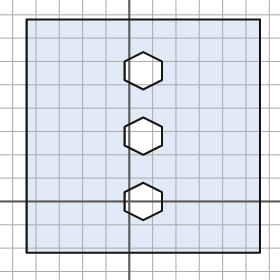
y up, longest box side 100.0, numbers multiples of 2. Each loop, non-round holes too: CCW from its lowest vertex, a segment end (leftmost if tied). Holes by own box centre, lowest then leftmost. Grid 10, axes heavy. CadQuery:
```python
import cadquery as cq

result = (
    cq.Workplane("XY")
    .moveTo(-44.0, -22.0)
    .lineTo(56.0, -22.0)
    .lineTo(56.0, 78.0)
    .lineTo(-44.0, 78.0)
    .close()
    .moveTo(6.0, -8.0)
    .lineTo(14.0, -4.0)
    .lineTo(14.0, 4.0)
    .lineTo(6.0, 8.0)
    .lineTo(-2.0, 4.0)
    .lineTo(-2.0, -4.0)
    .close()
    .moveTo(6.0, 20.0)
    .lineTo(14.0, 24.0)
    .lineTo(14.0, 32.0)
    .lineTo(6.0, 36.0)
    .lineTo(-2.0, 32.0)
    .lineTo(-2.0, 24.0)
    .close()
    .moveTo(6.0, 48.0)
    .lineTo(14.0, 52.0)
    .lineTo(14.0, 60.0)
    .lineTo(6.0, 64.0)
    .lineTo(-2.0, 60.0)
    .lineTo(-2.0, 52.0)
    .close()
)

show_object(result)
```